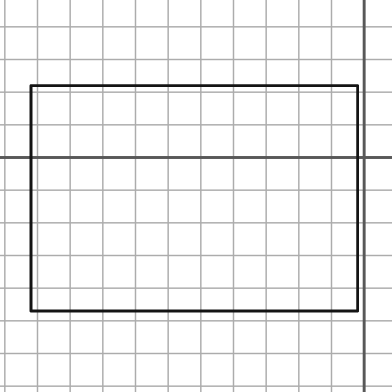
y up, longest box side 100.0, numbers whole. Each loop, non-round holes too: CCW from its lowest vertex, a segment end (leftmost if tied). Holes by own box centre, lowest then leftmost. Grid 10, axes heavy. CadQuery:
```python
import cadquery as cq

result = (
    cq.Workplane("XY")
    .moveTo(-102.0, -47.0)
    .lineTo(-2.0, -47.0)
    .lineTo(-2.0, 22.0)
    .lineTo(-102.0, 22.0)
    .close()
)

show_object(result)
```